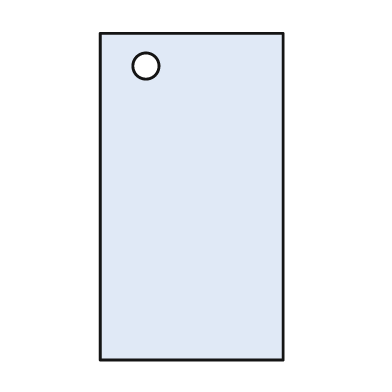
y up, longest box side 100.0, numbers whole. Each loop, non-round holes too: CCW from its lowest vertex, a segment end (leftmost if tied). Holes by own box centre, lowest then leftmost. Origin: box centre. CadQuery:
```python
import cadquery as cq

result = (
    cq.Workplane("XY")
    .moveTo(-28.0, -50.0)
    .lineTo(28.0, -50.0)
    .lineTo(28.0, 50.0)
    .lineTo(-28.0, 50.0)
    .close()
    .moveTo(-14.0, 40.0)
    .circle(4.0)
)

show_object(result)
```